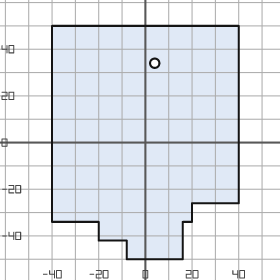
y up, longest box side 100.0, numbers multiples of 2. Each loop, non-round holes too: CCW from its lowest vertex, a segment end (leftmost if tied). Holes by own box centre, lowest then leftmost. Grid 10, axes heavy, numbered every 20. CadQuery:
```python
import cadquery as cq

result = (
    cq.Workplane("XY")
    .moveTo(-8.0, -50.0)
    .lineTo(16.0, -50.0)
    .lineTo(16.0, -34.0)
    .lineTo(20.0, -34.0)
    .lineTo(20.0, -26.0)
    .lineTo(40.0, -26.0)
    .lineTo(40.0, 50.0)
    .lineTo(-40.0, 50.0)
    .lineTo(-40.0, -34.0)
    .lineTo(-20.0, -34.0)
    .lineTo(-20.0, -42.0)
    .lineTo(-8.0, -42.0)
    .close()
    .moveTo(4.0, 34.0)
    .circle(2.0)
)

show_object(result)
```